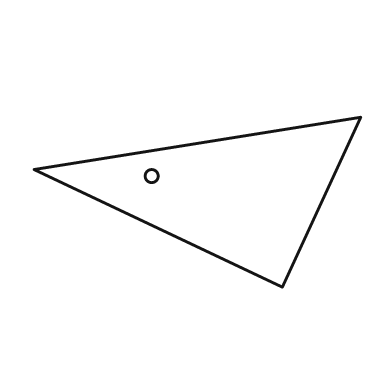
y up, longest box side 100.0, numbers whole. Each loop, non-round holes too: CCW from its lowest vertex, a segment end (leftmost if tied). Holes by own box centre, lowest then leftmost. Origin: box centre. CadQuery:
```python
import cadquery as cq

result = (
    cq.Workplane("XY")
    .moveTo(26.0, -26.0)
    .lineTo(50.0, 26.0)
    .lineTo(-50.0, 10.0)
    .close()
    .moveTo(-14.0, 8.0)
    .circle(2.0)
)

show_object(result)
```